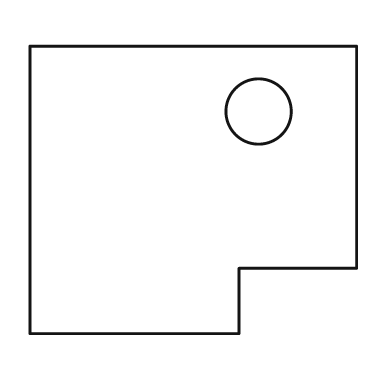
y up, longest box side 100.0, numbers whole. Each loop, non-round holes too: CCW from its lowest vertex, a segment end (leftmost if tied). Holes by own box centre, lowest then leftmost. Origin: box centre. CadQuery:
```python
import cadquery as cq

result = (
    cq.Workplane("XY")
    .moveTo(-50.0, -44.0)
    .lineTo(14.0, -44.0)
    .lineTo(14.0, -24.0)
    .lineTo(50.0, -24.0)
    .lineTo(50.0, 44.0)
    .lineTo(-50.0, 44.0)
    .close()
    .moveTo(20.0, 24.0)
    .circle(10.0)
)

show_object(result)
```